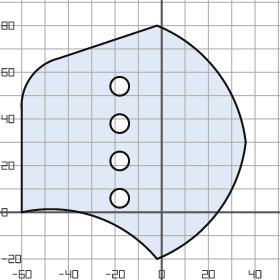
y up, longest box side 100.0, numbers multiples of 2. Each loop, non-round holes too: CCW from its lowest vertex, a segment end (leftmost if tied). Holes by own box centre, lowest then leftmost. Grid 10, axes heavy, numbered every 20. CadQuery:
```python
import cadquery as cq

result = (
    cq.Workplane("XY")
    .moveTo(-2.0, -20.0)
    .threePointArc((24.0, 0.0), (36.0, 30.0))
    .threePointArc((24.0, 60.0), (-2.0, 80.0))
    .lineTo(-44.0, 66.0)
    .threePointArc((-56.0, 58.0), (-60.0, 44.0))
    .lineTo(-60.0, 0.0)
    .threePointArc((-28.0, -2.0), (-2.0, -20.0))
    .close()
    .moveTo(-18.0, 6.0)
    .circle(4.0)
    .moveTo(-18.0, 22.0)
    .circle(4.0)
    .moveTo(-18.0, 38.0)
    .circle(4.0)
    .moveTo(-18.0, 54.0)
    .circle(4.0)
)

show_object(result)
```